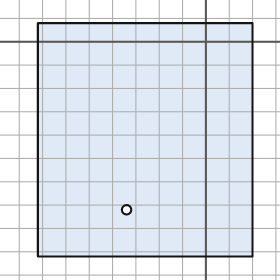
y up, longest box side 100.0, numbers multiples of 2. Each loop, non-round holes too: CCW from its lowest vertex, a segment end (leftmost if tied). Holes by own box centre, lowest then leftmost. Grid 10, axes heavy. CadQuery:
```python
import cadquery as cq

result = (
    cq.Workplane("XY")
    .moveTo(-72.0, -92.0)
    .lineTo(20.0, -92.0)
    .lineTo(20.0, 8.0)
    .lineTo(-72.0, 8.0)
    .close()
    .moveTo(-34.0, -72.0)
    .circle(2.0)
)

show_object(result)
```